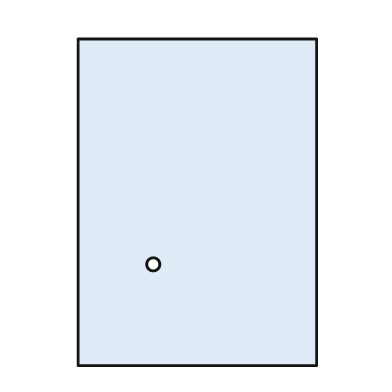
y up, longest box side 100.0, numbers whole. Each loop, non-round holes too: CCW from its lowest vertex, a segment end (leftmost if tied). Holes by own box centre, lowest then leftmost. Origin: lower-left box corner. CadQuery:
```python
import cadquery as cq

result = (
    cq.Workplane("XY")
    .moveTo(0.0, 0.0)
    .lineTo(73.0, 0.0)
    .lineTo(73.0, 100.0)
    .lineTo(0.0, 100.0)
    .close()
    .moveTo(23.0, 31.0)
    .circle(2.0)
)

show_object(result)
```